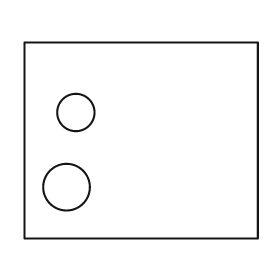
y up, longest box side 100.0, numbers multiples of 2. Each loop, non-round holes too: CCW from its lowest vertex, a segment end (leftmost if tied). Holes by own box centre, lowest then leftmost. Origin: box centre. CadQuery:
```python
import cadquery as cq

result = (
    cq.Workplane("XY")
    .moveTo(-50.0, -42.0)
    .lineTo(50.0, -42.0)
    .lineTo(50.0, 42.0)
    .lineTo(-50.0, 42.0)
    .close()
    .moveTo(-32.0, -20.0)
    .circle(10.0)
    .moveTo(-28.0, 12.0)
    .circle(8.0)
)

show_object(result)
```